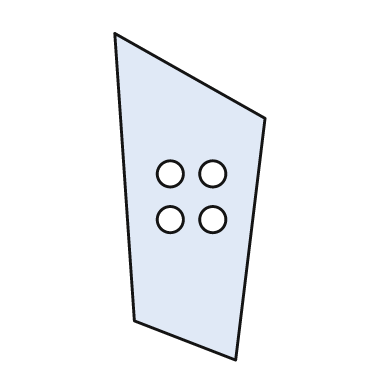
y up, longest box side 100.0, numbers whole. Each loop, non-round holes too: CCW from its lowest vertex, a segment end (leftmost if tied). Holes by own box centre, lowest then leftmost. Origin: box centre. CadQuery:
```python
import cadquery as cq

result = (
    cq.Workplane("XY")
    .moveTo(14.0, -50.0)
    .lineTo(23.0, 24.0)
    .lineTo(-23.0, 50.0)
    .lineTo(-17.0, -38.0)
    .close()
    .moveTo(-6.0, -7.0)
    .circle(4.0)
    .moveTo(7.0, -7.0)
    .circle(4.0)
    .moveTo(-6.0, 7.0)
    .circle(4.0)
    .moveTo(7.0, 7.0)
    .circle(4.0)
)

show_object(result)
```